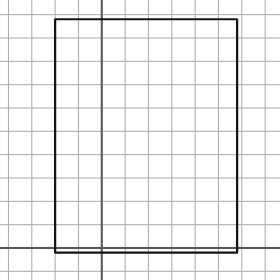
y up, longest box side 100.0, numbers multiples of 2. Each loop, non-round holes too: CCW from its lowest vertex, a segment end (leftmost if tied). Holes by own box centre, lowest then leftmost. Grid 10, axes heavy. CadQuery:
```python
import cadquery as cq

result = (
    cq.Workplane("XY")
    .moveTo(-20.0, -2.0)
    .lineTo(58.0, -2.0)
    .lineTo(58.0, 98.0)
    .lineTo(-20.0, 98.0)
    .close()
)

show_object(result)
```